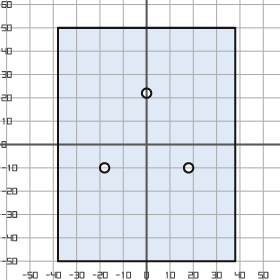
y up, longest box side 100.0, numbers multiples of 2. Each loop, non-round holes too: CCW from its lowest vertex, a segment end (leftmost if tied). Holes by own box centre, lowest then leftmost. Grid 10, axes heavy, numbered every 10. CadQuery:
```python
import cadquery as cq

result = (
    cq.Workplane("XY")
    .moveTo(-38.0, -50.0)
    .lineTo(38.0, -50.0)
    .lineTo(38.0, 50.0)
    .lineTo(-38.0, 50.0)
    .close()
    .moveTo(-18.0, -10.0)
    .circle(2.0)
    .moveTo(18.0, -10.0)
    .circle(2.0)
    .moveTo(0.0, 22.0)
    .circle(2.0)
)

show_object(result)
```